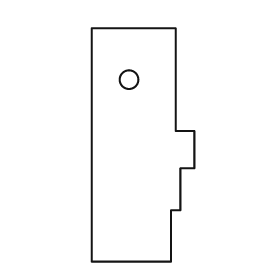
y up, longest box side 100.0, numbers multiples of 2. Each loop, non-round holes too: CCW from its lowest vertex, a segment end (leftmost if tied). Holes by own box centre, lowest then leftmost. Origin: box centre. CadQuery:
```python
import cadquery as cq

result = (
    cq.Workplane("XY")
    .moveTo(-22.0, -50.0)
    .lineTo(12.0, -50.0)
    .lineTo(12.0, -28.0)
    .lineTo(16.0, -28.0)
    .lineTo(16.0, -10.0)
    .lineTo(22.0, -10.0)
    .lineTo(22.0, 6.0)
    .lineTo(14.0, 6.0)
    .lineTo(14.0, 50.0)
    .lineTo(-22.0, 50.0)
    .close()
    .moveTo(-6.0, 28.0)
    .circle(4.0)
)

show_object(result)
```